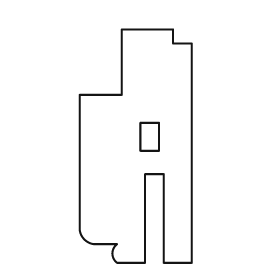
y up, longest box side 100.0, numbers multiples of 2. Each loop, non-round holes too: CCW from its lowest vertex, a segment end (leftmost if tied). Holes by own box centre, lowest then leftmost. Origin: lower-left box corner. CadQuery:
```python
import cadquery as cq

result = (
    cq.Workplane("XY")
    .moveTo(16.0, 0.0)
    .lineTo(28.0, 0.0)
    .lineTo(28.0, 38.0)
    .lineTo(36.0, 38.0)
    .lineTo(36.0, 0.0)
    .lineTo(48.0, 0.0)
    .lineTo(48.0, 94.0)
    .lineTo(40.0, 94.0)
    .lineTo(40.0, 100.0)
    .lineTo(18.0, 100.0)
    .lineTo(18.0, 72.0)
    .lineTo(0.0, 72.0)
    .lineTo(0.0, 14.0)
    .threePointArc((2.0, 10.0), (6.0, 8.0))
    .lineTo(16.0, 8.0)
    .threePointArc((14.0, 4.0), (16.0, 0.0))
    .close()
    .moveTo(26.0, 48.0)
    .lineTo(34.0, 48.0)
    .lineTo(34.0, 60.0)
    .lineTo(26.0, 60.0)
    .close()
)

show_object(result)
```